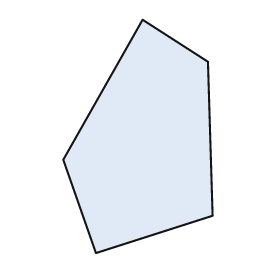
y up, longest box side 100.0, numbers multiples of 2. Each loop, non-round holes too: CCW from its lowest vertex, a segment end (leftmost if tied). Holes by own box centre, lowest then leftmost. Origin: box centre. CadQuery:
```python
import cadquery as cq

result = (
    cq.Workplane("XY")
    .moveTo(-18.0, -50.0)
    .lineTo(32.0, -34.0)
    .lineTo(30.0, 32.0)
    .lineTo(2.0, 50.0)
    .lineTo(-32.0, -10.0)
    .close()
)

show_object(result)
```